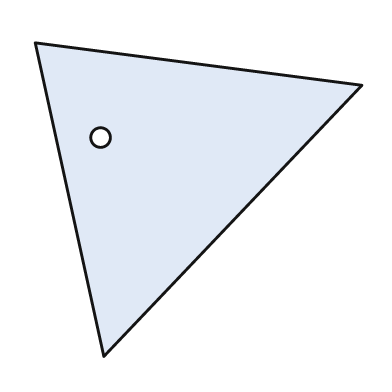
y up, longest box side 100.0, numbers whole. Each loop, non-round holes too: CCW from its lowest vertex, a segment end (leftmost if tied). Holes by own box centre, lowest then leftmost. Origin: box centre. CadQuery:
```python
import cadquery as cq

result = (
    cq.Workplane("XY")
    .moveTo(-29.0, -48.0)
    .lineTo(50.0, 35.0)
    .lineTo(-50.0, 48.0)
    .close()
    .moveTo(-30.0, 19.0)
    .circle(3.0)
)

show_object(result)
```